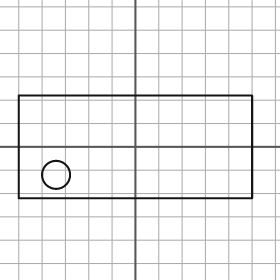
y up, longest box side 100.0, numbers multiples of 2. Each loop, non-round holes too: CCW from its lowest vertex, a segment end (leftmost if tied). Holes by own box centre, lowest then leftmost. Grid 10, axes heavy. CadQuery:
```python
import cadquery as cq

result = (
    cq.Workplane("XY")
    .moveTo(-50.0, -22.0)
    .lineTo(50.0, -22.0)
    .lineTo(50.0, 22.0)
    .lineTo(-50.0, 22.0)
    .close()
    .moveTo(-34.0, -12.0)
    .circle(6.0)
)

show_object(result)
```